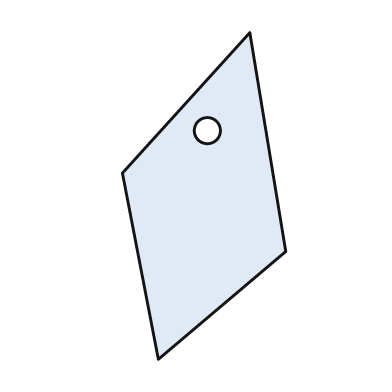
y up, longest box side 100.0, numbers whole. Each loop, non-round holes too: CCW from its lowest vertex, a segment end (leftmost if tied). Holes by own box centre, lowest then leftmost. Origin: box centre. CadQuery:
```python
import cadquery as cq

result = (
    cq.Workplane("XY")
    .moveTo(-14.0, -50.0)
    .lineTo(25.0, -17.0)
    .lineTo(14.0, 50.0)
    .lineTo(-25.0, 7.0)
    .close()
    .moveTo(1.0, 20.0)
    .circle(4.0)
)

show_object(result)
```